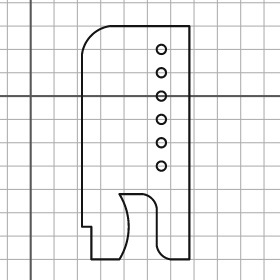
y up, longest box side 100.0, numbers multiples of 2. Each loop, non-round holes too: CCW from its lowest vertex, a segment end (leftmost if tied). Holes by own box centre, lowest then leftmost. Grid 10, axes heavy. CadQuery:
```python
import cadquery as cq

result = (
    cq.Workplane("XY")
    .moveTo(26.0, -70.0)
    .lineTo(38.0, -70.0)
    .threePointArc((42.0, -56.0), (38.0, -42.0))
    .lineTo(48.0, -42.0)
    .threePointArc((52.0, -44.0), (54.0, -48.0))
    .lineTo(54.0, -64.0)
    .threePointArc((56.0, -68.0), (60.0, -70.0))
    .lineTo(68.0, -70.0)
    .lineTo(68.0, 30.0)
    .lineTo(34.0, 30.0)
    .threePointArc((26.0, 26.0), (22.0, 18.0))
    .lineTo(22.0, -56.0)
    .lineTo(26.0, -56.0)
    .close()
    .moveTo(56.0, -30.0)
    .circle(2.0)
    .moveTo(56.0, -20.0)
    .circle(2.0)
    .moveTo(56.0, -10.0)
    .circle(2.0)
    .moveTo(56.0, 0.0)
    .circle(2.0)
    .moveTo(56.0, 10.0)
    .circle(2.0)
    .moveTo(56.0, 20.0)
    .circle(2.0)
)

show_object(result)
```